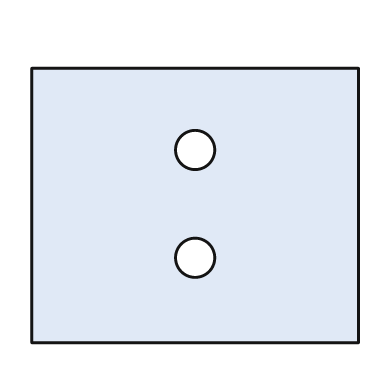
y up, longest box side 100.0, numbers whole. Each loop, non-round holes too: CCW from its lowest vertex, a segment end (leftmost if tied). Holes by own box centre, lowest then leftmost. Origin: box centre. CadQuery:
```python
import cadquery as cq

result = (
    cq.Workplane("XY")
    .moveTo(-50.0, -42.0)
    .lineTo(50.0, -42.0)
    .lineTo(50.0, 42.0)
    .lineTo(-50.0, 42.0)
    .close()
    .moveTo(0.0, -16.0)
    .circle(6.0)
    .moveTo(0.0, 17.0)
    .circle(6.0)
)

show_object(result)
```